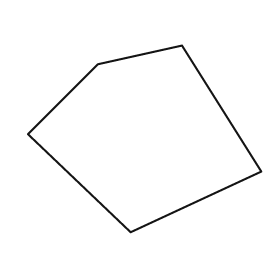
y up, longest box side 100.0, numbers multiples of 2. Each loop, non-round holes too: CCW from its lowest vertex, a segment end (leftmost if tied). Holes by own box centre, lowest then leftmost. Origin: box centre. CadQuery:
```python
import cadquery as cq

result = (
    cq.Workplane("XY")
    .moveTo(-6.0, -40.0)
    .lineTo(50.0, -14.0)
    .lineTo(16.0, 40.0)
    .lineTo(-20.0, 32.0)
    .lineTo(-50.0, 2.0)
    .close()
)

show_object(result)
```